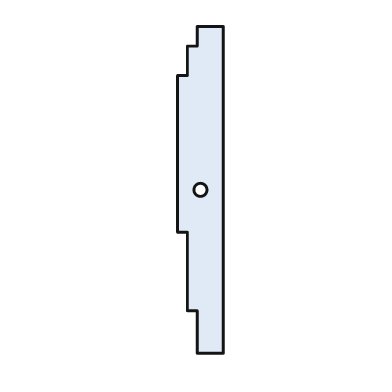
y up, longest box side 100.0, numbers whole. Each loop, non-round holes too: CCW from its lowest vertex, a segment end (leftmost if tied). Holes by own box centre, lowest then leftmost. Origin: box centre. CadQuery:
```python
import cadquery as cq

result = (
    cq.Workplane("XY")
    .moveTo(-1.0, -50.0)
    .lineTo(7.0, -50.0)
    .lineTo(7.0, 50.0)
    .lineTo(-1.0, 50.0)
    .lineTo(-1.0, 44.0)
    .lineTo(-4.0, 44.0)
    .lineTo(-4.0, 35.0)
    .lineTo(-7.0, 35.0)
    .lineTo(-7.0, -13.0)
    .lineTo(-4.0, -13.0)
    .lineTo(-4.0, -37.0)
    .lineTo(-1.0, -37.0)
    .close()
    .moveTo(0.0, 0.0)
    .circle(2.0)
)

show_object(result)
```